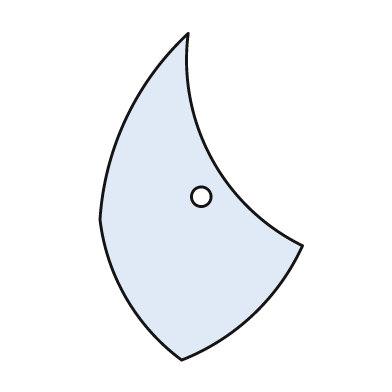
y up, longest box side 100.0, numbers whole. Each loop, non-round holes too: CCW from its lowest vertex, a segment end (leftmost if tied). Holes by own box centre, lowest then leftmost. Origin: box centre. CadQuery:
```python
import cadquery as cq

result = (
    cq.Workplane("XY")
    .moveTo(-6.0, -50.0)
    .threePointArc((16.0, -36.0), (31.0, -15.0))
    .threePointArc((3.0, 12.0), (-4.0, 50.0))
    .threePointArc((-23.0, 24.0), (-31.0, -7.0))
    .threePointArc((-23.0, -31.0), (-6.0, -50.0))
    .close()
    .moveTo(0.0, 0.0)
    .circle(3.0)
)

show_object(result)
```